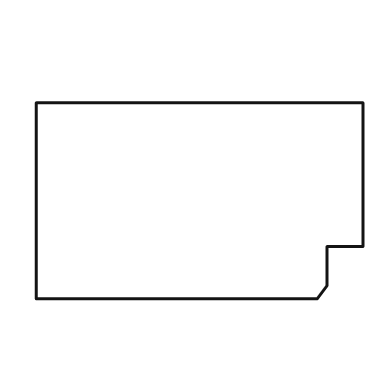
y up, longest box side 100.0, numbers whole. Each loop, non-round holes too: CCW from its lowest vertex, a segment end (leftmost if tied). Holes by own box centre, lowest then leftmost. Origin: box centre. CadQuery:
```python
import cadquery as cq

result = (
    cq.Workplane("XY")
    .moveTo(-50.0, -30.0)
    .lineTo(36.0, -30.0)
    .lineTo(39.0, -26.0)
    .lineTo(39.0, -14.0)
    .lineTo(50.0, -14.0)
    .lineTo(50.0, 30.0)
    .lineTo(-50.0, 30.0)
    .close()
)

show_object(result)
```